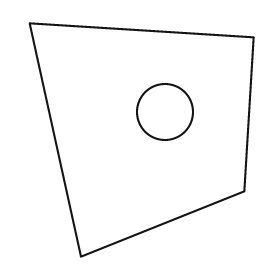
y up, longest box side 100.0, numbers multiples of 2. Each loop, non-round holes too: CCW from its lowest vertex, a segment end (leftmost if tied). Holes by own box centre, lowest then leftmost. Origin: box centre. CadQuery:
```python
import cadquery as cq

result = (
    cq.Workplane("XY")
    .moveTo(-26.0, -50.0)
    .lineTo(44.0, -22.0)
    .lineTo(48.0, 44.0)
    .lineTo(-48.0, 50.0)
    .close()
    .moveTo(10.0, 12.0)
    .circle(12.0)
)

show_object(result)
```